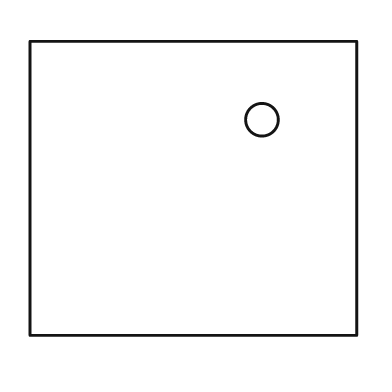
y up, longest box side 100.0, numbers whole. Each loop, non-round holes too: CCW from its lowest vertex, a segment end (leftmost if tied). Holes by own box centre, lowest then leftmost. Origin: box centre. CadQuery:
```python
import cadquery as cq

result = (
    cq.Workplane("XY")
    .moveTo(-50.0, -45.0)
    .lineTo(50.0, -45.0)
    .lineTo(50.0, 45.0)
    .lineTo(-50.0, 45.0)
    .close()
    .moveTo(21.0, 21.0)
    .circle(5.0)
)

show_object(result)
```